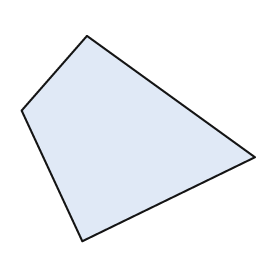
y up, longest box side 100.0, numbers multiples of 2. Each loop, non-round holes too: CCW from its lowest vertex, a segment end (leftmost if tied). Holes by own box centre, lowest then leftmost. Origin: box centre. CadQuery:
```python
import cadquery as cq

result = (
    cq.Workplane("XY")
    .moveTo(-24.0, -44.0)
    .lineTo(50.0, -8.0)
    .lineTo(-22.0, 44.0)
    .lineTo(-50.0, 12.0)
    .close()
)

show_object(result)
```